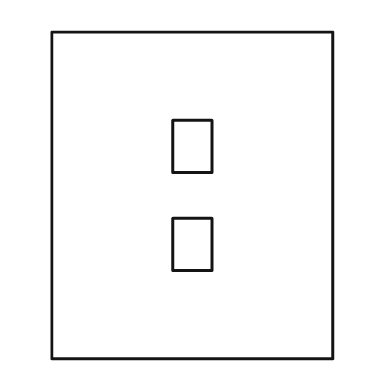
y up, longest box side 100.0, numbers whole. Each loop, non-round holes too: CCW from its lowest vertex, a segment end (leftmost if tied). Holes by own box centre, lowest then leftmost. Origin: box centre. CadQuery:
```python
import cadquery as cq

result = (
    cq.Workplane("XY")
    .moveTo(-43.0, -50.0)
    .lineTo(43.0, -50.0)
    .lineTo(43.0, 50.0)
    .lineTo(-43.0, 50.0)
    .close()
    .moveTo(-6.0, -23.0)
    .lineTo(6.0, -23.0)
    .lineTo(6.0, -7.0)
    .lineTo(-6.0, -7.0)
    .close()
    .moveTo(-6.0, 7.0)
    .lineTo(6.0, 7.0)
    .lineTo(6.0, 23.0)
    .lineTo(-6.0, 23.0)
    .close()
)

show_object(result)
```